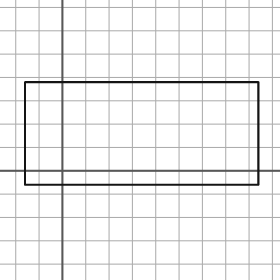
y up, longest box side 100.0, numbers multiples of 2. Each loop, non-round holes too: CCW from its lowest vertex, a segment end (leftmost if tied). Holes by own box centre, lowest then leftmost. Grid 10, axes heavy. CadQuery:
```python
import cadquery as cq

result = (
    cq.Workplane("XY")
    .moveTo(-16.0, -6.0)
    .lineTo(84.0, -6.0)
    .lineTo(84.0, 38.0)
    .lineTo(-16.0, 38.0)
    .close()
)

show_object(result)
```